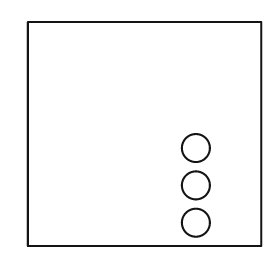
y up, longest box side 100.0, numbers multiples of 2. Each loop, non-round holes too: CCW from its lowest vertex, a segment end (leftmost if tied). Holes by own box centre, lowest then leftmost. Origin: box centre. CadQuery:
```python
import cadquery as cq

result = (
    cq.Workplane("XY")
    .moveTo(-50.0, -48.0)
    .lineTo(50.0, -48.0)
    .lineTo(50.0, 48.0)
    .lineTo(-50.0, 48.0)
    .close()
    .moveTo(22.0, -38.0)
    .circle(6.0)
    .moveTo(22.0, -22.0)
    .circle(6.0)
    .moveTo(22.0, -6.0)
    .circle(6.0)
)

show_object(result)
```